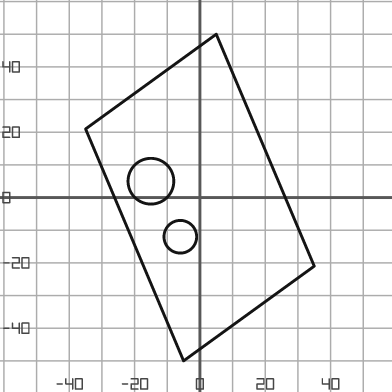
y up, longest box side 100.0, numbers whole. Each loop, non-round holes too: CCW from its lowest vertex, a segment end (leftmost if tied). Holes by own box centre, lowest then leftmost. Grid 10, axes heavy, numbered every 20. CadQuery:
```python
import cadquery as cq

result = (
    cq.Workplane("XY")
    .moveTo(-5.0, -50.0)
    .lineTo(35.0, -21.0)
    .lineTo(5.0, 50.0)
    .lineTo(-35.0, 21.0)
    .close()
    .moveTo(-6.0, -12.0)
    .circle(5.0)
    .moveTo(-15.0, 5.0)
    .circle(7.0)
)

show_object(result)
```